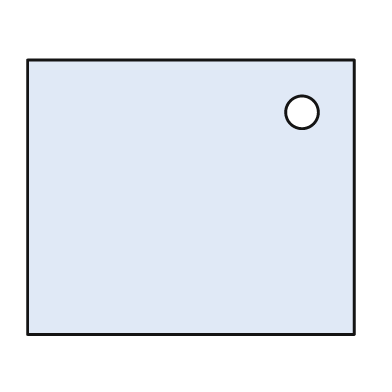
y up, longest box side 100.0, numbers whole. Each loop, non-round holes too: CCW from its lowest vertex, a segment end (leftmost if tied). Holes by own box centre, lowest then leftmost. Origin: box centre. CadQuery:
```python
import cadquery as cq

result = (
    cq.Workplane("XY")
    .moveTo(-50.0, -42.0)
    .lineTo(50.0, -42.0)
    .lineTo(50.0, 42.0)
    .lineTo(-50.0, 42.0)
    .close()
    .moveTo(34.0, 26.0)
    .circle(5.0)
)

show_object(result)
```